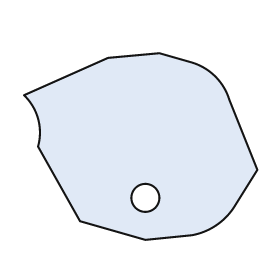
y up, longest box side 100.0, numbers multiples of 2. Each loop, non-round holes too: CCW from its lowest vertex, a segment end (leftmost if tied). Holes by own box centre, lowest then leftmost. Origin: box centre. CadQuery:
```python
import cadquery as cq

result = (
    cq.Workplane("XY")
    .moveTo(2.0, -40.0)
    .lineTo(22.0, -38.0)
    .threePointArc((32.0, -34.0), (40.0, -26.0))
    .lineTo(50.0, -10.0)
    .lineTo(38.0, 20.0)
    .threePointArc((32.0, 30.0), (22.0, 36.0))
    .lineTo(8.0, 40.0)
    .lineTo(-14.0, 38.0)
    .lineTo(-50.0, 22.0)
    .threePointArc((-44.0, 12.0), (-44.0, 0.0))
    .lineTo(-26.0, -32.0)
    .close()
    .moveTo(2.0, -22.0)
    .circle(6.0)
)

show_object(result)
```